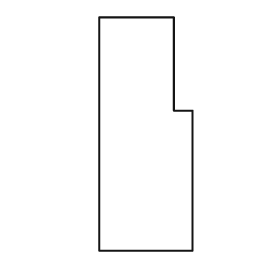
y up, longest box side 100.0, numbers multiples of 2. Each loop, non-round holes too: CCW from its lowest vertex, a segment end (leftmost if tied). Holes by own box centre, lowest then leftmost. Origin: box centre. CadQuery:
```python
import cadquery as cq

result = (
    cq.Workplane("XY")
    .moveTo(-20.0, -50.0)
    .lineTo(20.0, -50.0)
    .lineTo(20.0, 10.0)
    .lineTo(12.0, 10.0)
    .lineTo(12.0, 50.0)
    .lineTo(-20.0, 50.0)
    .close()
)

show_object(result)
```